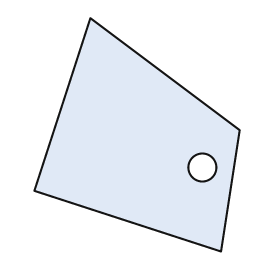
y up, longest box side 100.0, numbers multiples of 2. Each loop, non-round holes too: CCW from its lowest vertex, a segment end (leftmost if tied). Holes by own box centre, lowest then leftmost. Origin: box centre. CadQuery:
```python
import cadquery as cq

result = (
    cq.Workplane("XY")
    .moveTo(36.0, -50.0)
    .lineTo(44.0, 2.0)
    .lineTo(-20.0, 50.0)
    .lineTo(-44.0, -24.0)
    .close()
    .moveTo(28.0, -14.0)
    .circle(6.0)
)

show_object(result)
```